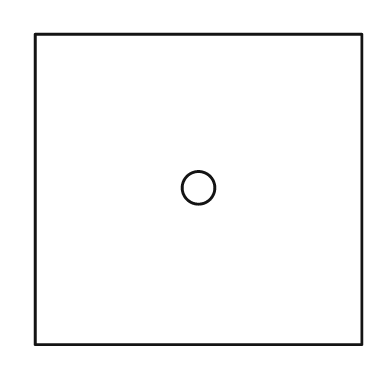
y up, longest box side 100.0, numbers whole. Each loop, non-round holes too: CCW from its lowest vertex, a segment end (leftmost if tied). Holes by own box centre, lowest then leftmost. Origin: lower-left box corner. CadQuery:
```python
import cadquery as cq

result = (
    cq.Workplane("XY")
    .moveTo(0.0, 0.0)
    .lineTo(100.0, 0.0)
    .lineTo(100.0, 95.0)
    .lineTo(0.0, 95.0)
    .close()
    .moveTo(50.0, 48.0)
    .circle(5.0)
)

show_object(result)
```